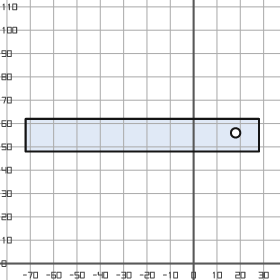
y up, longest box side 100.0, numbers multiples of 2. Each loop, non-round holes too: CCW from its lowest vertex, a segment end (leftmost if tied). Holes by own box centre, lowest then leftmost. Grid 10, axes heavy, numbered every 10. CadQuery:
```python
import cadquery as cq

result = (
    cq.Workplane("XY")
    .moveTo(-72.0, 48.0)
    .lineTo(28.0, 48.0)
    .lineTo(28.0, 62.0)
    .lineTo(-72.0, 62.0)
    .close()
    .moveTo(18.0, 56.0)
    .circle(2.0)
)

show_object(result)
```